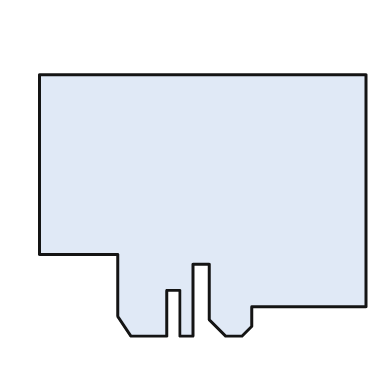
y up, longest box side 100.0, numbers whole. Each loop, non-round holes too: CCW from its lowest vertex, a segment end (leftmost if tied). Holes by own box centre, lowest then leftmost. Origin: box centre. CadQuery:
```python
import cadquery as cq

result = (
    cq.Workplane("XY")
    .moveTo(-22.0, -40.0)
    .lineTo(-11.0, -40.0)
    .lineTo(-11.0, -26.0)
    .lineTo(-7.0, -26.0)
    .lineTo(-7.0, -40.0)
    .lineTo(-3.0, -40.0)
    .lineTo(-3.0, -18.0)
    .lineTo(2.0, -18.0)
    .lineTo(2.0, -35.0)
    .lineTo(7.0, -40.0)
    .lineTo(12.0, -40.0)
    .lineTo(15.0, -37.0)
    .lineTo(15.0, -31.0)
    .lineTo(50.0, -31.0)
    .lineTo(50.0, 40.0)
    .lineTo(-50.0, 40.0)
    .lineTo(-50.0, -15.0)
    .lineTo(-26.0, -15.0)
    .lineTo(-26.0, -34.0)
    .close()
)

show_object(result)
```